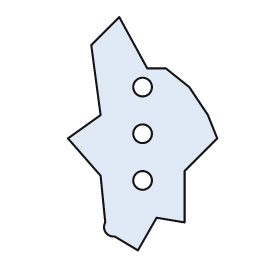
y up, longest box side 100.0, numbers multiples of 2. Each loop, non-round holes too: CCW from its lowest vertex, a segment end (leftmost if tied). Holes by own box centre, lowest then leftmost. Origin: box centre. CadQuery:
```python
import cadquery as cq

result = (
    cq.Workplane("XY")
    .moveTo(-2.0, -50.0)
    .lineTo(6.0, -36.0)
    .lineTo(18.0, -38.0)
    .lineTo(18.0, -16.0)
    .lineTo(32.0, -2.0)
    .lineTo(28.0, 8.0)
    .lineTo(20.0, 20.0)
    .lineTo(10.0, 28.0)
    .lineTo(2.0, 28.0)
    .lineTo(-10.0, 50.0)
    .lineTo(-22.0, 38.0)
    .lineTo(-18.0, 8.0)
    .lineTo(-32.0, -2.0)
    .lineTo(-18.0, -18.0)
    .lineTo(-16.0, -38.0)
    .threePointArc((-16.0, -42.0), (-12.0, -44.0))
    .close()
    .moveTo(0.0, -20.0)
    .circle(4.0)
    .moveTo(0.0, 0.0)
    .circle(4.0)
    .moveTo(0.0, 20.0)
    .circle(4.0)
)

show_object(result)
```